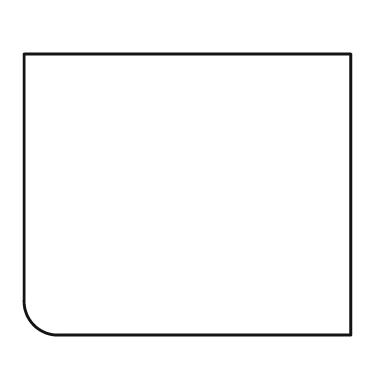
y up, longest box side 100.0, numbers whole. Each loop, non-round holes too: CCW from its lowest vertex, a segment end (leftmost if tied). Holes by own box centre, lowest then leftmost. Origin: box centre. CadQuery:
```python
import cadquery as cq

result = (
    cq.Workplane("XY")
    .moveTo(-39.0, -43.0)
    .lineTo(50.0, -43.0)
    .lineTo(50.0, 43.0)
    .lineTo(-50.0, 43.0)
    .lineTo(-50.0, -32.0)
    .threePointArc((-47.0, -40.0), (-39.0, -43.0))
    .close()
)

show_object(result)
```